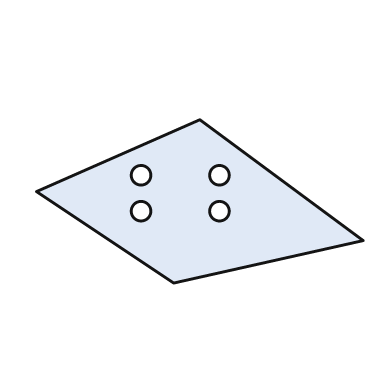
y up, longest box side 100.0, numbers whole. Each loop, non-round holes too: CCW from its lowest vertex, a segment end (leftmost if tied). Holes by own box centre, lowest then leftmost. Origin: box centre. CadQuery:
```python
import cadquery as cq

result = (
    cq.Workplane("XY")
    .moveTo(-8.0, -25.0)
    .lineTo(50.0, -12.0)
    .lineTo(0.0, 25.0)
    .lineTo(-50.0, 3.0)
    .close()
    .moveTo(-18.0, -3.0)
    .circle(3.0)
    .moveTo(6.0, -3.0)
    .circle(3.0)
    .moveTo(-18.0, 8.0)
    .circle(3.0)
    .moveTo(6.0, 8.0)
    .circle(3.0)
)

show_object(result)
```